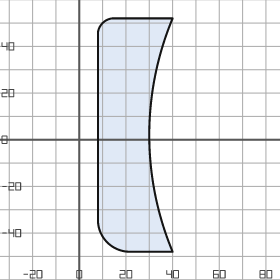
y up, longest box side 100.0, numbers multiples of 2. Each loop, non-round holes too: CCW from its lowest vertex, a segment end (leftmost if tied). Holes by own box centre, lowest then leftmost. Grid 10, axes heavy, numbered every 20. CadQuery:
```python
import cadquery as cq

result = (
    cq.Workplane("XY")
    .moveTo(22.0, -48.0)
    .lineTo(40.0, -48.0)
    .threePointArc((30.0, 2.0), (40.0, 52.0))
    .lineTo(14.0, 52.0)
    .threePointArc((10.0, 50.0), (8.0, 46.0))
    .lineTo(8.0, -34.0)
    .threePointArc((12.0, -44.0), (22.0, -48.0))
    .close()
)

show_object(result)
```